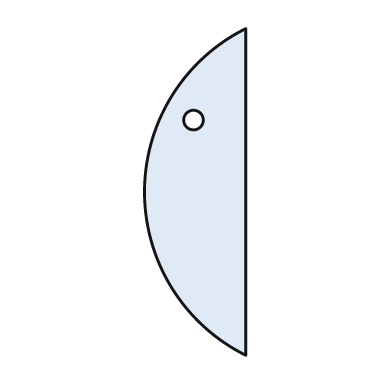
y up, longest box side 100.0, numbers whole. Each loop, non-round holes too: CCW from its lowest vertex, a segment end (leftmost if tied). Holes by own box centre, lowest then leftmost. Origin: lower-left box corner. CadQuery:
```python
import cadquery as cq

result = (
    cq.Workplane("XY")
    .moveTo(31.0, 0.0)
    .lineTo(31.0, 100.0)
    .threePointArc((0.0, 50.0), (31.0, 0.0))
    .close()
    .moveTo(15.0, 72.0)
    .circle(3.0)
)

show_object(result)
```